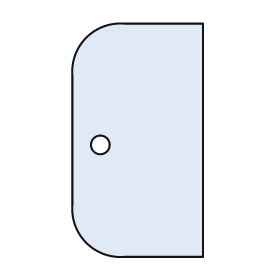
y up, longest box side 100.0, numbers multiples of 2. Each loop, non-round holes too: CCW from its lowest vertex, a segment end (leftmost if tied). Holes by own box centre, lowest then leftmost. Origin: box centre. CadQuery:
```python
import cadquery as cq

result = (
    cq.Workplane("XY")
    .moveTo(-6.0, -50.0)
    .lineTo(28.0, -50.0)
    .lineTo(28.0, 50.0)
    .lineTo(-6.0, 50.0)
    .threePointArc((-22.0, 44.0), (-28.0, 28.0))
    .lineTo(-28.0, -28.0)
    .threePointArc((-22.0, -44.0), (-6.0, -50.0))
    .close()
    .moveTo(-16.0, -2.0)
    .circle(4.0)
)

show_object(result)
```